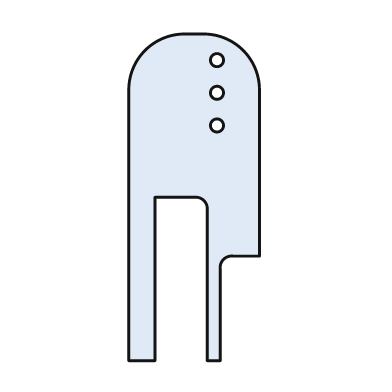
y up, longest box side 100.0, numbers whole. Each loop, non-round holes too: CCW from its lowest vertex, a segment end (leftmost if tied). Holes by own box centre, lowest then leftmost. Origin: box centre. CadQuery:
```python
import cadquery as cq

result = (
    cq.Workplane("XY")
    .moveTo(-20.0, -50.0)
    .lineTo(-12.0, -50.0)
    .lineTo(-12.0, 0.0)
    .lineTo(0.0, 0.0)
    .threePointArc((3.0, -1.0), (4.0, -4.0))
    .lineTo(4.0, -50.0)
    .lineTo(8.0, -50.0)
    .lineTo(8.0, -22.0)
    .threePointArc((9.0, -19.0), (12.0, -18.0))
    .lineTo(20.0, -18.0)
    .lineTo(20.0, 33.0)
    .threePointArc((15.0, 45.0), (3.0, 50.0))
    .lineTo(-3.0, 50.0)
    .threePointArc((-15.0, 45.0), (-20.0, 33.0))
    .close()
    .moveTo(7.0, 22.0)
    .circle(2.0)
    .moveTo(7.0, 32.0)
    .circle(2.0)
    .moveTo(7.0, 42.0)
    .circle(2.0)
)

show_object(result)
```